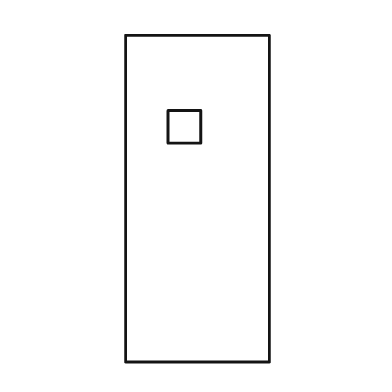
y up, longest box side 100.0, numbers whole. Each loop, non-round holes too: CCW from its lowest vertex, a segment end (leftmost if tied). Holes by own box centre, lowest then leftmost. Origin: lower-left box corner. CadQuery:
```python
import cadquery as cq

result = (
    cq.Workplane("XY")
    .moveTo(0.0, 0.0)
    .lineTo(44.0, 0.0)
    .lineTo(44.0, 100.0)
    .lineTo(0.0, 100.0)
    .close()
    .moveTo(13.0, 67.0)
    .lineTo(23.0, 67.0)
    .lineTo(23.0, 77.0)
    .lineTo(13.0, 77.0)
    .close()
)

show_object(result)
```